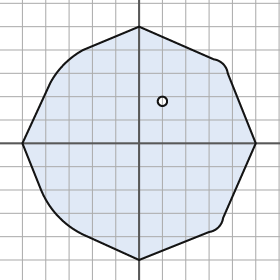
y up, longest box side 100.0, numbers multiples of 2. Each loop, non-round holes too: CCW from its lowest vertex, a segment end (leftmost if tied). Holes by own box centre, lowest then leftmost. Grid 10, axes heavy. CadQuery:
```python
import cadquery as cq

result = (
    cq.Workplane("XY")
    .moveTo(0.0, -50.0)
    .lineTo(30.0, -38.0)
    .threePointArc((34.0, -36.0), (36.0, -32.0))
    .lineTo(50.0, 0.0)
    .lineTo(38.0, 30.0)
    .threePointArc((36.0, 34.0), (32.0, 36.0))
    .lineTo(0.0, 50.0)
    .lineTo(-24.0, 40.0)
    .threePointArc((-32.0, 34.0), (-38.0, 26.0))
    .lineTo(-50.0, 0.0)
    .lineTo(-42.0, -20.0)
    .threePointArc((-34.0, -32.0), (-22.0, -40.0))
    .close()
    .moveTo(10.0, 18.0)
    .circle(2.0)
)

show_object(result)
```